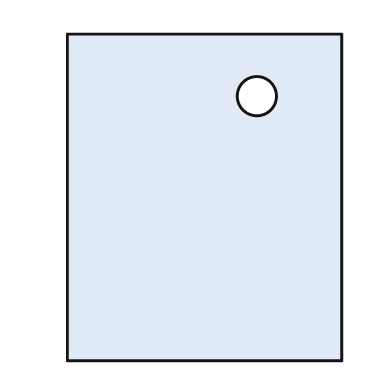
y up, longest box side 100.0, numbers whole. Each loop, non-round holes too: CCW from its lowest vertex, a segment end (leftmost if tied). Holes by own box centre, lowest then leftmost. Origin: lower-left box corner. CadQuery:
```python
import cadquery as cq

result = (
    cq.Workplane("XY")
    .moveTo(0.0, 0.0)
    .lineTo(84.0, 0.0)
    .lineTo(84.0, 100.0)
    .lineTo(0.0, 100.0)
    .close()
    .moveTo(58.0, 81.0)
    .circle(6.0)
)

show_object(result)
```